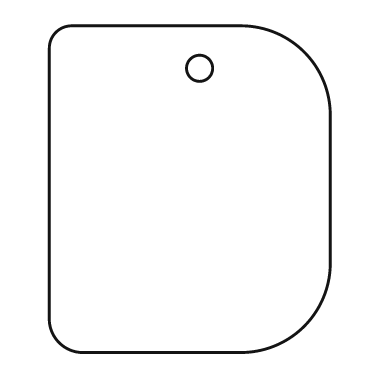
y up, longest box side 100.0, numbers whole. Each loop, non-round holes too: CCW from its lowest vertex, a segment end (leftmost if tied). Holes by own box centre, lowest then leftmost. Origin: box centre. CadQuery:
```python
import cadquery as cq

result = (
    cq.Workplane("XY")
    .moveTo(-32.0, -50.0)
    .lineTo(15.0, -50.0)
    .threePointArc((35.0, -42.0), (43.0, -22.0))
    .lineTo(43.0, 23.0)
    .threePointArc((35.0, 42.0), (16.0, 50.0))
    .lineTo(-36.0, 50.0)
    .threePointArc((-41.0, 48.0), (-43.0, 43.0))
    .lineTo(-43.0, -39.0)
    .threePointArc((-40.0, -47.0), (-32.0, -50.0))
    .close()
    .moveTo(3.0, 37.0)
    .circle(4.0)
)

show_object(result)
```